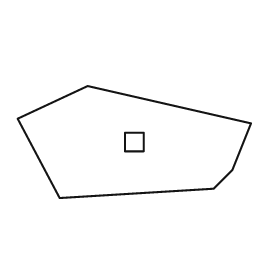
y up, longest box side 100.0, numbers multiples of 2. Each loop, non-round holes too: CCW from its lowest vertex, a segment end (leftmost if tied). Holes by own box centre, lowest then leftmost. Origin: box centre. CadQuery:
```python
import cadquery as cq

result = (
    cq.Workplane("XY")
    .moveTo(-32.0, -24.0)
    .lineTo(34.0, -20.0)
    .lineTo(42.0, -12.0)
    .lineTo(50.0, 8.0)
    .lineTo(-20.0, 24.0)
    .lineTo(-50.0, 10.0)
    .close()
    .moveTo(-4.0, -4.0)
    .lineTo(4.0, -4.0)
    .lineTo(4.0, 4.0)
    .lineTo(-4.0, 4.0)
    .close()
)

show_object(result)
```